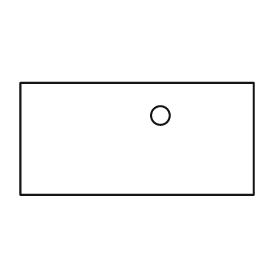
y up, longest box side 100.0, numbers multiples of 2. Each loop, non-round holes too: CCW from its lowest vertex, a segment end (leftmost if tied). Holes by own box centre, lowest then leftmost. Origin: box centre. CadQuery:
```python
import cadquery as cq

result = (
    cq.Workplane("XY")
    .moveTo(-50.0, -24.0)
    .lineTo(50.0, -24.0)
    .lineTo(50.0, 24.0)
    .lineTo(-50.0, 24.0)
    .close()
    .moveTo(10.0, 10.0)
    .circle(4.0)
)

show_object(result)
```